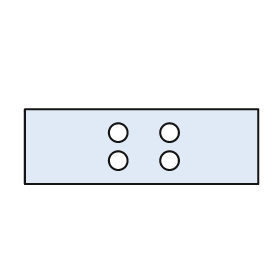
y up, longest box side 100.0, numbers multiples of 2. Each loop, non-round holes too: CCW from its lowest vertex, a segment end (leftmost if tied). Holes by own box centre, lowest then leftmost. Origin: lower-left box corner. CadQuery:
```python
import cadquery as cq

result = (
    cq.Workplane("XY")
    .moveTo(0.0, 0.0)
    .lineTo(100.0, 0.0)
    .lineTo(100.0, 32.0)
    .lineTo(0.0, 32.0)
    .close()
    .moveTo(40.0, 10.0)
    .circle(4.0)
    .moveTo(62.0, 10.0)
    .circle(4.0)
    .moveTo(40.0, 22.0)
    .circle(4.0)
    .moveTo(62.0, 22.0)
    .circle(4.0)
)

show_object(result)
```